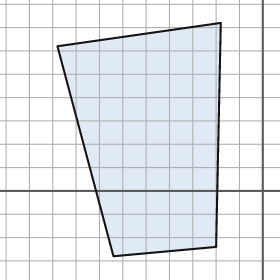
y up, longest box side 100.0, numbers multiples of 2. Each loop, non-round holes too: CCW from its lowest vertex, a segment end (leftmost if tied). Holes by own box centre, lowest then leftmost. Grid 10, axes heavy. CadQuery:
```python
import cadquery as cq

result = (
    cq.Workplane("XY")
    .moveTo(-64.0, -28.0)
    .lineTo(-20.0, -24.0)
    .lineTo(-18.0, 72.0)
    .lineTo(-88.0, 62.0)
    .close()
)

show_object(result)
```